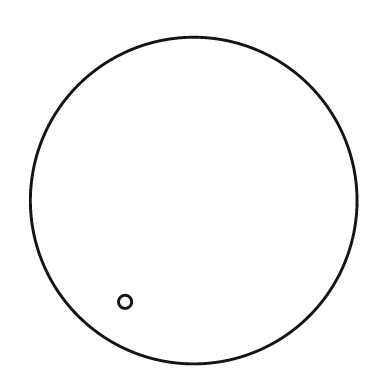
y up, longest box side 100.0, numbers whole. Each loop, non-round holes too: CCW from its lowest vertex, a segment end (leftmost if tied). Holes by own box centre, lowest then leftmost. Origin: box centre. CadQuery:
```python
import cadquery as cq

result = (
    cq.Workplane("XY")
    .moveTo(0.0, 0.0)
    .circle(50.0)
    .moveTo(-21.0, -31.0)
    .circle(2.0)
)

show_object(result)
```